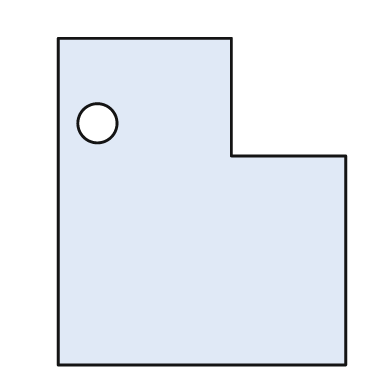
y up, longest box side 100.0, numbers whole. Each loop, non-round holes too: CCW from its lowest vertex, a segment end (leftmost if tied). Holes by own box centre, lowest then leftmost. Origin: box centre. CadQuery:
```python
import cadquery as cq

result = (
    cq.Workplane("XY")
    .moveTo(-44.0, -50.0)
    .lineTo(44.0, -50.0)
    .lineTo(44.0, 14.0)
    .lineTo(9.0, 14.0)
    .lineTo(9.0, 50.0)
    .lineTo(-44.0, 50.0)
    .close()
    .moveTo(-32.0, 24.0)
    .circle(6.0)
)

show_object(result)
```